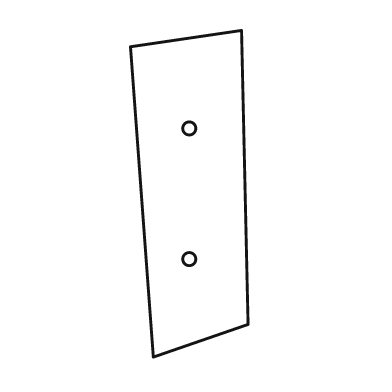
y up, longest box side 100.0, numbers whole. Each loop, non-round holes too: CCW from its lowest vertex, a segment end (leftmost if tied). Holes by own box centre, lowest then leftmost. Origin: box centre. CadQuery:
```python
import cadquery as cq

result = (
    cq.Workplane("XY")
    .moveTo(-11.0, -50.0)
    .lineTo(18.0, -40.0)
    .lineTo(16.0, 50.0)
    .lineTo(-18.0, 45.0)
    .close()
    .moveTo(0.0, -20.0)
    .circle(2.0)
    .moveTo(0.0, 20.0)
    .circle(2.0)
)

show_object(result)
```